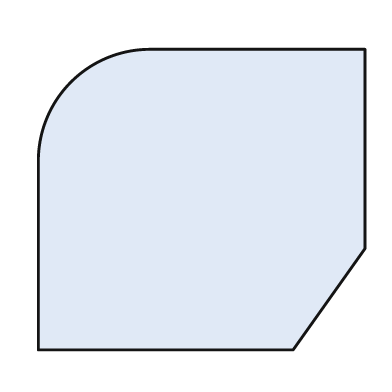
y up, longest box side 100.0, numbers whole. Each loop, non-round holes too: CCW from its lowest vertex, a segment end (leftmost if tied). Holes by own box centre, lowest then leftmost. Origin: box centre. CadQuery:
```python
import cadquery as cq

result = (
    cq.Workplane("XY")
    .moveTo(-50.0, -46.0)
    .lineTo(28.0, -46.0)
    .lineTo(50.0, -15.0)
    .lineTo(50.0, 46.0)
    .lineTo(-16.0, 46.0)
    .threePointArc((-40.0, 36.0), (-50.0, 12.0))
    .close()
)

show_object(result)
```